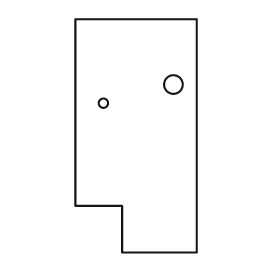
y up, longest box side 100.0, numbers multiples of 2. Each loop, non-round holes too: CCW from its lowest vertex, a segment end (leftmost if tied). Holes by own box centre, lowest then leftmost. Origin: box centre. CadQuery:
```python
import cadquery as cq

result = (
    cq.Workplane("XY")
    .moveTo(-6.0, -50.0)
    .lineTo(26.0, -50.0)
    .lineTo(26.0, 50.0)
    .lineTo(-26.0, 50.0)
    .lineTo(-26.0, -30.0)
    .lineTo(-6.0, -30.0)
    .close()
    .moveTo(-14.0, 14.0)
    .circle(2.0)
    .moveTo(16.0, 22.0)
    .circle(4.0)
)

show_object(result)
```